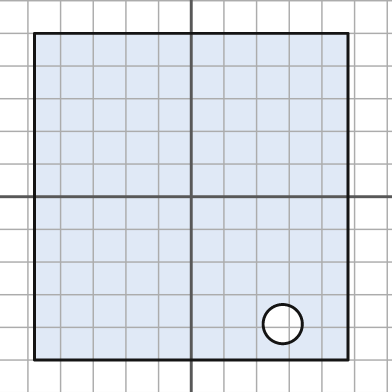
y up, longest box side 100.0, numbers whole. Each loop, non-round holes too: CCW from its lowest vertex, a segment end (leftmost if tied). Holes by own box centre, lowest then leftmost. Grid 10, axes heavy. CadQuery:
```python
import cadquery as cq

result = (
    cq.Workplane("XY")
    .moveTo(-48.0, -50.0)
    .lineTo(48.0, -50.0)
    .lineTo(48.0, 50.0)
    .lineTo(-48.0, 50.0)
    .close()
    .moveTo(28.0, -39.0)
    .circle(6.0)
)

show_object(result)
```